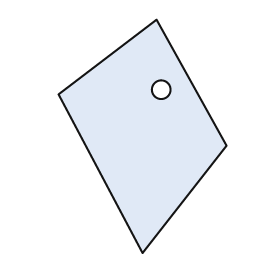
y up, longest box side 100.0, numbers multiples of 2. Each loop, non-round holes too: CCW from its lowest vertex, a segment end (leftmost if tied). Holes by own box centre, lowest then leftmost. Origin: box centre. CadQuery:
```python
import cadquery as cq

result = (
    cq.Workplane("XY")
    .moveTo(0.0, -50.0)
    .lineTo(36.0, -4.0)
    .lineTo(6.0, 50.0)
    .lineTo(-36.0, 18.0)
    .close()
    .moveTo(8.0, 20.0)
    .circle(4.0)
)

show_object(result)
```